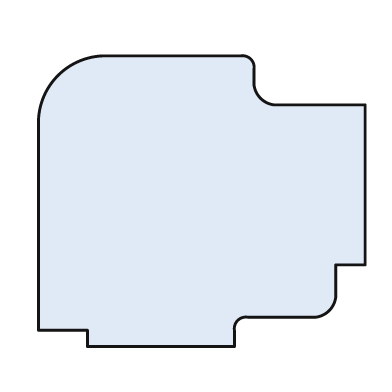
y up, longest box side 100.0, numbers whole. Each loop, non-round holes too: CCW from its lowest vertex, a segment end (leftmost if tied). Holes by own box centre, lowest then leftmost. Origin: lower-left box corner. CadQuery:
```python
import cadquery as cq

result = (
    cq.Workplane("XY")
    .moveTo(15.0, 0.0)
    .lineTo(60.0, 0.0)
    .lineTo(60.0, 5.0)
    .threePointArc((61.0, 8.0), (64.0, 9.0))
    .lineTo(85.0, 9.0)
    .threePointArc((89.0, 11.0), (91.0, 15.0))
    .lineTo(91.0, 25.0)
    .lineTo(100.0, 25.0)
    .lineTo(100.0, 74.0)
    .lineTo(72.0, 74.0)
    .threePointArc((68.0, 76.0), (66.0, 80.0))
    .lineTo(66.0, 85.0)
    .threePointArc((65.0, 88.0), (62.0, 89.0))
    .lineTo(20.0, 89.0)
    .threePointArc((6.0, 83.0), (0.0, 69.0))
    .lineTo(0.0, 5.0)
    .lineTo(15.0, 5.0)
    .close()
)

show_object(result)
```